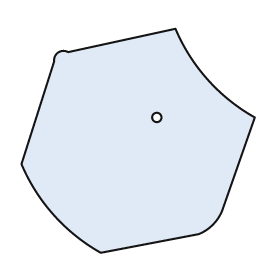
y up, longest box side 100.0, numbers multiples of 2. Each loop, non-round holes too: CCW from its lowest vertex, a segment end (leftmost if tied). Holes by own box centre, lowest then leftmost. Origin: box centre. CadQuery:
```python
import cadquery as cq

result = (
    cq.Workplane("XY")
    .moveTo(-16.0, -48.0)
    .lineTo(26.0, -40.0)
    .threePointArc((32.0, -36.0), (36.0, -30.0))
    .lineTo(50.0, 10.0)
    .threePointArc((30.0, 26.0), (16.0, 48.0))
    .lineTo(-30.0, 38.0)
    .threePointArc((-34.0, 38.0), (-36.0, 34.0))
    .lineTo(-50.0, -10.0)
    .threePointArc((-36.0, -32.0), (-16.0, -48.0))
    .close()
    .moveTo(8.0, 10.0)
    .circle(2.0)
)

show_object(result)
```